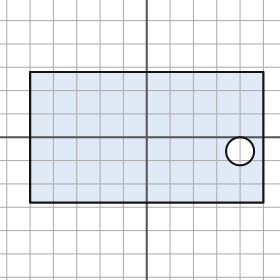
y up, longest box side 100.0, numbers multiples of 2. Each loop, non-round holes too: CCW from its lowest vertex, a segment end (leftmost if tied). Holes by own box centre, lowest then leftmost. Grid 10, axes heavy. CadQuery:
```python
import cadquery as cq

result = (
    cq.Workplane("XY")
    .moveTo(-50.0, -28.0)
    .lineTo(50.0, -28.0)
    .lineTo(50.0, 28.0)
    .lineTo(-50.0, 28.0)
    .close()
    .moveTo(40.0, -6.0)
    .circle(6.0)
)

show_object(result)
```